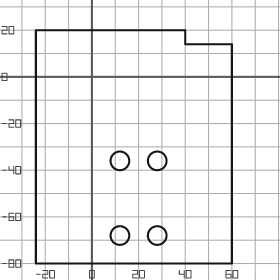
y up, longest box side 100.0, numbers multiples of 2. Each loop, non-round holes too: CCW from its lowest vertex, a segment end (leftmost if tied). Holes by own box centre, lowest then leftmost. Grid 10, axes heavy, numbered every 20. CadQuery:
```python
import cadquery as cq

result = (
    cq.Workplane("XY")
    .moveTo(-24.0, -80.0)
    .lineTo(60.0, -80.0)
    .lineTo(60.0, 14.0)
    .lineTo(40.0, 14.0)
    .lineTo(40.0, 20.0)
    .lineTo(-24.0, 20.0)
    .close()
    .moveTo(12.0, -68.0)
    .circle(4.0)
    .moveTo(28.0, -68.0)
    .circle(4.0)
    .moveTo(12.0, -36.0)
    .circle(4.0)
    .moveTo(28.0, -36.0)
    .circle(4.0)
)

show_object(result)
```